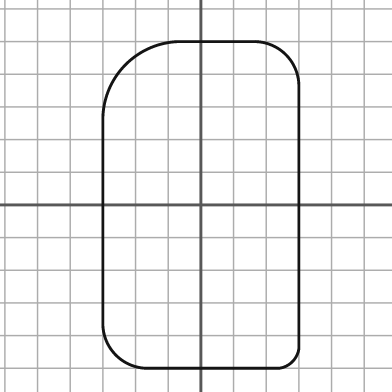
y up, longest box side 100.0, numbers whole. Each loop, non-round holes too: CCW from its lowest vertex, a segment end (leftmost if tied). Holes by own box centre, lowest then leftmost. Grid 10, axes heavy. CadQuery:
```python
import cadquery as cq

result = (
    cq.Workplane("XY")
    .moveTo(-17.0, -50.0)
    .lineTo(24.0, -50.0)
    .threePointArc((28.0, -48.0), (30.0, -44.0))
    .lineTo(30.0, 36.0)
    .threePointArc((26.0, 46.0), (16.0, 50.0))
    .lineTo(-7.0, 50.0)
    .threePointArc((-23.0, 43.0), (-30.0, 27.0))
    .lineTo(-30.0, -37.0)
    .threePointArc((-26.0, -46.0), (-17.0, -50.0))
    .close()
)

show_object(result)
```